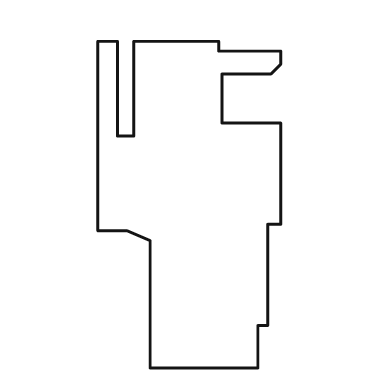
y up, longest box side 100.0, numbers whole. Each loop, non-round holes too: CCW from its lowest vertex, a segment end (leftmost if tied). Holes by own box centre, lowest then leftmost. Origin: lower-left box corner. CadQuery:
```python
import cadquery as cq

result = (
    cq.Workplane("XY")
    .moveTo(16.0, 0.0)
    .lineTo(49.0, 0.0)
    .lineTo(49.0, 13.0)
    .lineTo(52.0, 13.0)
    .lineTo(52.0, 44.0)
    .lineTo(56.0, 44.0)
    .lineTo(56.0, 75.0)
    .lineTo(38.0, 75.0)
    .lineTo(38.0, 90.0)
    .lineTo(53.0, 90.0)
    .lineTo(56.0, 93.0)
    .lineTo(56.0, 97.0)
    .lineTo(37.0, 97.0)
    .lineTo(37.0, 100.0)
    .lineTo(11.0, 100.0)
    .lineTo(11.0, 71.0)
    .lineTo(6.0, 71.0)
    .lineTo(6.0, 100.0)
    .lineTo(0.0, 100.0)
    .lineTo(0.0, 42.0)
    .lineTo(9.0, 42.0)
    .lineTo(16.0, 39.0)
    .close()
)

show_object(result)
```